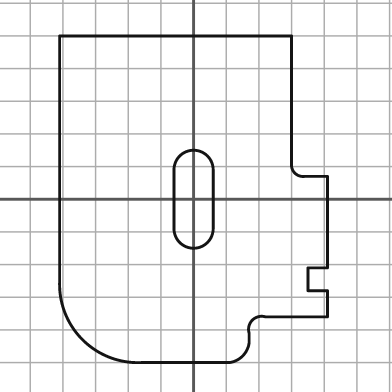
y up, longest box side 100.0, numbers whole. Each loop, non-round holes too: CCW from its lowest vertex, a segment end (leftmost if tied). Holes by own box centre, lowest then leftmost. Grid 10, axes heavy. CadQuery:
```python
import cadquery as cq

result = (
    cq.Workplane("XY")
    .moveTo(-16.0, -50.0)
    .lineTo(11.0, -50.0)
    .threePointArc((15.0, -48.0), (17.0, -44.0))
    .lineTo(17.0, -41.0)
    .threePointArc((18.0, -37.0), (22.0, -36.0))
    .lineTo(41.0, -36.0)
    .lineTo(41.0, -28.0)
    .lineTo(35.0, -28.0)
    .lineTo(35.0, -21.0)
    .lineTo(41.0, -21.0)
    .lineTo(41.0, 7.0)
    .lineTo(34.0, 7.0)
    .threePointArc((31.0, 8.0), (30.0, 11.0))
    .lineTo(30.0, 50.0)
    .lineTo(-41.0, 50.0)
    .lineTo(-41.0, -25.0)
    .threePointArc((-34.0, -43.0), (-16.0, -50.0))
    .close()
    .moveTo(-6.0, -9.0)
    .threePointArc((0.0, -15.0), (6.0, -9.0))
    .lineTo(6.0, 9.0)
    .threePointArc((0.0, 15.0), (-6.0, 9.0))
    .close()
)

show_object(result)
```